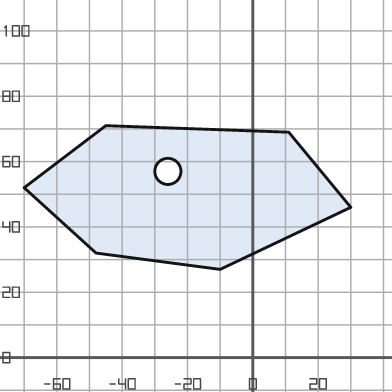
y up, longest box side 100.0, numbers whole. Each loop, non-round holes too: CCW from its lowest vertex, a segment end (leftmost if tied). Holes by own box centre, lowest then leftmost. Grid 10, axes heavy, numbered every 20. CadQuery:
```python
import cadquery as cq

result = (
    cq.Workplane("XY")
    .moveTo(-10.0, 27.0)
    .lineTo(30.0, 46.0)
    .lineTo(11.0, 69.0)
    .lineTo(-45.0, 71.0)
    .lineTo(-70.0, 52.0)
    .lineTo(-48.0, 32.0)
    .close()
    .moveTo(-26.0, 57.0)
    .circle(4.0)
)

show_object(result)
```